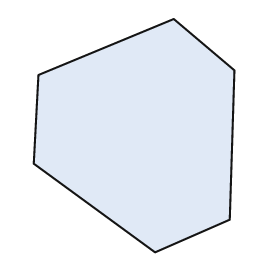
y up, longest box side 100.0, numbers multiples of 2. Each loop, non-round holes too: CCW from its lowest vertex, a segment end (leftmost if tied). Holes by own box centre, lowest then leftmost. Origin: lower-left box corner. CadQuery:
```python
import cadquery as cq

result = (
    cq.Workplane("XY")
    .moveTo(52.0, 0.0)
    .lineTo(84.0, 14.0)
    .lineTo(86.0, 78.0)
    .lineTo(60.0, 100.0)
    .lineTo(2.0, 76.0)
    .lineTo(0.0, 38.0)
    .close()
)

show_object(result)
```